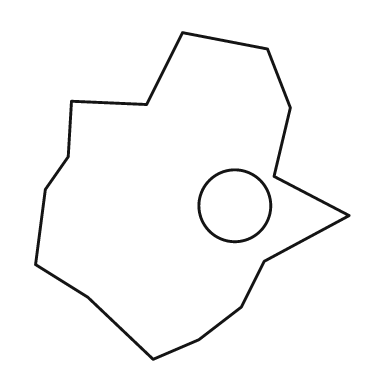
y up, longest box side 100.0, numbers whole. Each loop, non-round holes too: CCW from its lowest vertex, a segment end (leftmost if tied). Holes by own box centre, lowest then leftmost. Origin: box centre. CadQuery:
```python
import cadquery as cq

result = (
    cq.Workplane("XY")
    .moveTo(-12.0, -50.0)
    .lineTo(2.0, -44.0)
    .lineTo(15.0, -34.0)
    .lineTo(22.0, -20.0)
    .lineTo(48.0, -6.0)
    .lineTo(25.0, 6.0)
    .lineTo(30.0, 27.0)
    .lineTo(23.0, 45.0)
    .lineTo(-3.0, 50.0)
    .lineTo(-14.0, 28.0)
    .lineTo(-37.0, 29.0)
    .lineTo(-38.0, 12.0)
    .lineTo(-45.0, 2.0)
    .lineTo(-48.0, -21.0)
    .lineTo(-32.0, -31.0)
    .close()
    .moveTo(13.0, -3.0)
    .circle(11.0)
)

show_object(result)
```